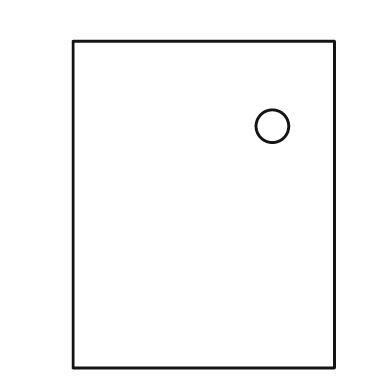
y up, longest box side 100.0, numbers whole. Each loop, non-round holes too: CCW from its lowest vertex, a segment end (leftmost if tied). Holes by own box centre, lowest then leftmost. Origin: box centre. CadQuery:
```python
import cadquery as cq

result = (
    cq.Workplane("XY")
    .moveTo(-40.0, -50.0)
    .lineTo(40.0, -50.0)
    .lineTo(40.0, 50.0)
    .lineTo(-40.0, 50.0)
    .close()
    .moveTo(21.0, 24.0)
    .circle(5.0)
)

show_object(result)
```